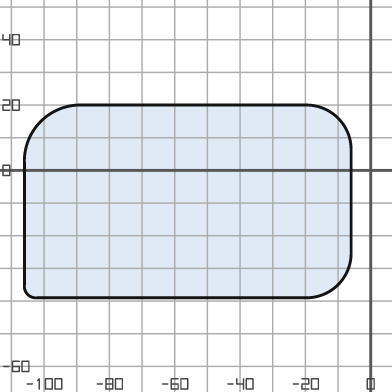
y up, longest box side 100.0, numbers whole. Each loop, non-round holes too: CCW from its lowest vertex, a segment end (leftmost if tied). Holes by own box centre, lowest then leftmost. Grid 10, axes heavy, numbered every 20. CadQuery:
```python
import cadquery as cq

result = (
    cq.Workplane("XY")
    .moveTo(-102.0, -39.0)
    .lineTo(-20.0, -39.0)
    .threePointArc((-10.0, -35.0), (-6.0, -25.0))
    .lineTo(-6.0, 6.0)
    .threePointArc((-10.0, 16.0), (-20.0, 20.0))
    .lineTo(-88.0, 20.0)
    .threePointArc((-101.0, 15.0), (-106.0, 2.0))
    .lineTo(-106.0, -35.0)
    .threePointArc((-105.0, -38.0), (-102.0, -39.0))
    .close()
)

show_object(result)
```